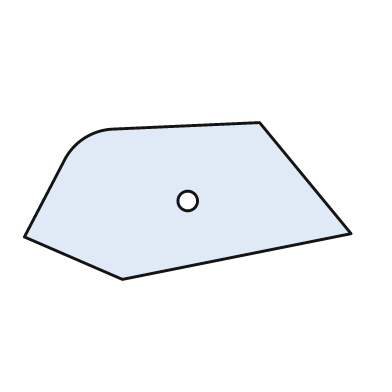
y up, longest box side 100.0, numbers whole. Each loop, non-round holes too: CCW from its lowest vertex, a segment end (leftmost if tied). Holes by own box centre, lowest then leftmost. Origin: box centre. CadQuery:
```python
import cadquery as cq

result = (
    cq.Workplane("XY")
    .moveTo(-20.0, -24.0)
    .lineTo(50.0, -10.0)
    .lineTo(22.0, 24.0)
    .lineTo(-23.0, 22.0)
    .threePointArc((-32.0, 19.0), (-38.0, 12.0))
    .lineTo(-50.0, -11.0)
    .close()
    .moveTo(0.0, 0.0)
    .circle(3.0)
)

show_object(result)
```